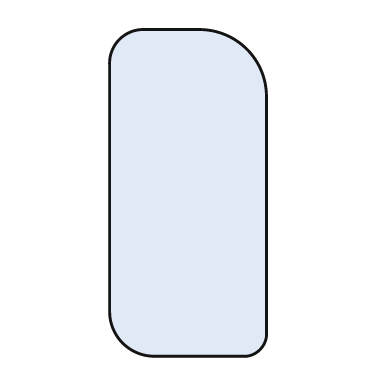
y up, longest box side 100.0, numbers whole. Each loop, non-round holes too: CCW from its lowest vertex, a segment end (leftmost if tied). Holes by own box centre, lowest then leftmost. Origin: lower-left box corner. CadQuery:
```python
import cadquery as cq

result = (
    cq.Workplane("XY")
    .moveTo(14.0, 0.0)
    .lineTo(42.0, 0.0)
    .threePointArc((46.0, 2.0), (48.0, 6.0))
    .lineTo(48.0, 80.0)
    .threePointArc((42.0, 94.0), (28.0, 100.0))
    .lineTo(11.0, 100.0)
    .threePointArc((3.0, 97.0), (0.0, 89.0))
    .lineTo(0.0, 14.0)
    .threePointArc((4.0, 4.0), (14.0, 0.0))
    .close()
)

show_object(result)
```